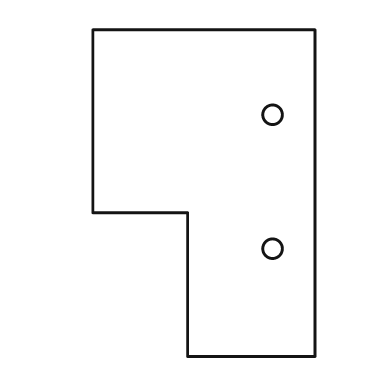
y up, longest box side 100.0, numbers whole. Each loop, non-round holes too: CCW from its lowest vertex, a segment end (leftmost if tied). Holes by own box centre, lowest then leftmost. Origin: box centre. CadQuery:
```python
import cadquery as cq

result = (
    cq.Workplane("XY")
    .moveTo(-5.0, -50.0)
    .lineTo(34.0, -50.0)
    .lineTo(34.0, 50.0)
    .lineTo(-34.0, 50.0)
    .lineTo(-34.0, -6.0)
    .lineTo(-5.0, -6.0)
    .close()
    .moveTo(21.0, -17.0)
    .circle(3.0)
    .moveTo(21.0, 24.0)
    .circle(3.0)
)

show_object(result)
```